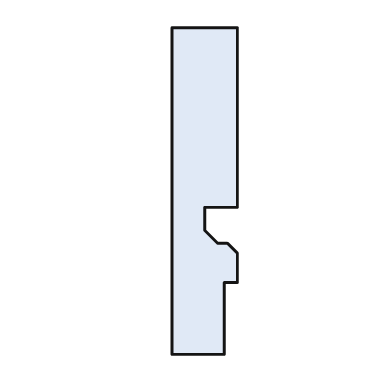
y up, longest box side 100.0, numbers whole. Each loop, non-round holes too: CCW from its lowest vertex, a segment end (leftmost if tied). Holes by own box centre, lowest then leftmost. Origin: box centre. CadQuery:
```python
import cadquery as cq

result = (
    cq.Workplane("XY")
    .moveTo(-10.0, -50.0)
    .lineTo(6.0, -50.0)
    .lineTo(6.0, -28.0)
    .lineTo(10.0, -28.0)
    .lineTo(10.0, -19.0)
    .lineTo(7.0, -16.0)
    .lineTo(4.0, -16.0)
    .lineTo(0.0, -12.0)
    .lineTo(0.0, -5.0)
    .lineTo(10.0, -5.0)
    .lineTo(10.0, 50.0)
    .lineTo(-10.0, 50.0)
    .close()
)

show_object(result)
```